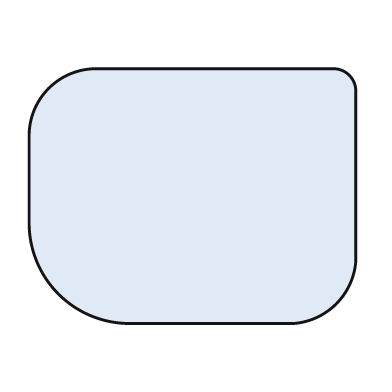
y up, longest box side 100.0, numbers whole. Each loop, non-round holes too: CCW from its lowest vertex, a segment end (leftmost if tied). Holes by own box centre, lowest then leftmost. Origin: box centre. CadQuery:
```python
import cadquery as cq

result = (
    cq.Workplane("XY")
    .moveTo(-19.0, -39.0)
    .lineTo(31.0, -39.0)
    .threePointArc((44.0, -33.0), (50.0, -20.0))
    .lineTo(50.0, 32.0)
    .threePointArc((48.0, 37.0), (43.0, 39.0))
    .lineTo(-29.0, 39.0)
    .threePointArc((-44.0, 33.0), (-50.0, 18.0))
    .lineTo(-50.0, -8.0)
    .threePointArc((-41.0, -30.0), (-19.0, -39.0))
    .close()
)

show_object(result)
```